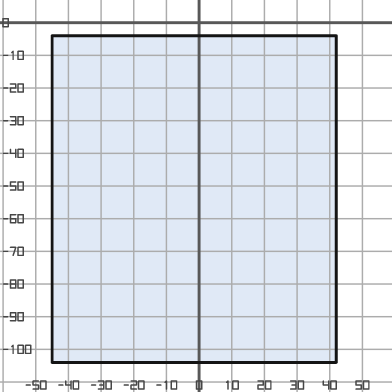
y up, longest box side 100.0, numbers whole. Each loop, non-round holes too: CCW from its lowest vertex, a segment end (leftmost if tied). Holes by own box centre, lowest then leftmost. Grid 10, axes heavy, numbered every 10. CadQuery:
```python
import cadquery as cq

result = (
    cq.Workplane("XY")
    .moveTo(-45.0, -104.0)
    .lineTo(42.0, -104.0)
    .lineTo(42.0, -4.0)
    .lineTo(-45.0, -4.0)
    .close()
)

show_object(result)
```